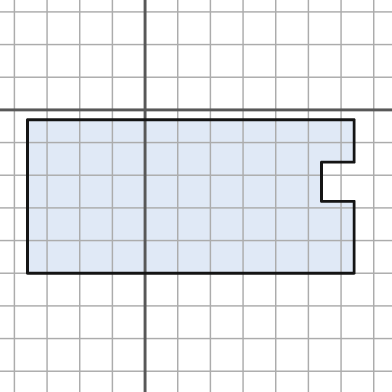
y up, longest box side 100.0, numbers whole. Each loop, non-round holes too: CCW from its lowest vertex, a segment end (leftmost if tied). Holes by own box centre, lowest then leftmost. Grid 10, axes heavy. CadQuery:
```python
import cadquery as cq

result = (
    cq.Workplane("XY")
    .moveTo(-36.0, -50.0)
    .lineTo(64.0, -50.0)
    .lineTo(64.0, -28.0)
    .lineTo(54.0, -28.0)
    .lineTo(54.0, -16.0)
    .lineTo(64.0, -16.0)
    .lineTo(64.0, -3.0)
    .lineTo(-36.0, -3.0)
    .close()
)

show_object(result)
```